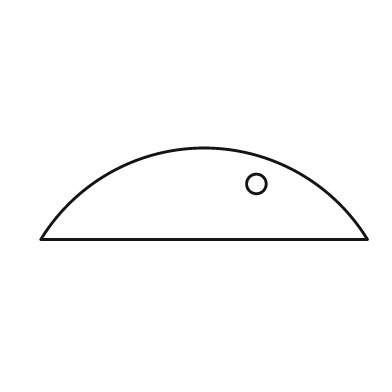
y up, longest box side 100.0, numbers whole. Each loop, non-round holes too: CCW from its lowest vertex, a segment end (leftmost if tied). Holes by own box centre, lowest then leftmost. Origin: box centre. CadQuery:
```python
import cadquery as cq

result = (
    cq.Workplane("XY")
    .moveTo(-50.0, -14.0)
    .lineTo(50.0, -14.0)
    .threePointArc((0.0, 14.0), (-50.0, -14.0))
    .close()
    .moveTo(16.0, 3.0)
    .circle(3.0)
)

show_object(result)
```